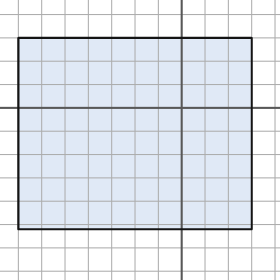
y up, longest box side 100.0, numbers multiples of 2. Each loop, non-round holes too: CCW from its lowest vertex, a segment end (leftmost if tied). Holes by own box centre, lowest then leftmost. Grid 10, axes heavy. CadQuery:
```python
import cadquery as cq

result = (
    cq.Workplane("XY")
    .moveTo(-70.0, -52.0)
    .lineTo(30.0, -52.0)
    .lineTo(30.0, 30.0)
    .lineTo(-70.0, 30.0)
    .close()
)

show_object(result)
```